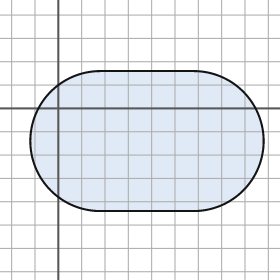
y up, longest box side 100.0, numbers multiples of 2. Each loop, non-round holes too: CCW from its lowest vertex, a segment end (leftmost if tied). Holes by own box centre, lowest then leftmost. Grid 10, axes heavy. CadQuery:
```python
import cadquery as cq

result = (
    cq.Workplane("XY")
    .moveTo(18.0, -44.0)
    .lineTo(58.0, -44.0)
    .threePointArc((88.0, -14.0), (58.0, 16.0))
    .lineTo(18.0, 16.0)
    .threePointArc((-12.0, -14.0), (18.0, -44.0))
    .close()
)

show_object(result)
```